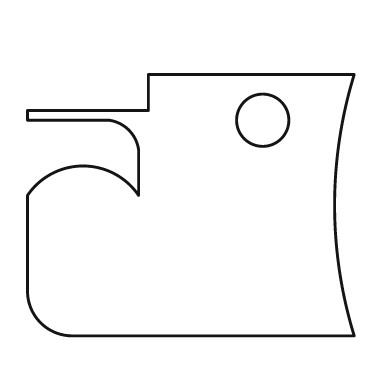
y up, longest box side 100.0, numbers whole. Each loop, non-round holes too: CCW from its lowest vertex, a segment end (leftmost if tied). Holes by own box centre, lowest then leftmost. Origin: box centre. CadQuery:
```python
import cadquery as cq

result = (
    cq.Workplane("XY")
    .moveTo(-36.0, -40.0)
    .lineTo(50.0, -40.0)
    .threePointArc((44.0, 0.0), (50.0, 40.0))
    .lineTo(-13.0, 40.0)
    .lineTo(-13.0, 29.0)
    .lineTo(-50.0, 29.0)
    .lineTo(-50.0, 26.0)
    .lineTo(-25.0, 26.0)
    .threePointArc((-19.0, 23.0), (-16.0, 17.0))
    .lineTo(-16.0, 3.0)
    .threePointArc((-33.0, 12.0), (-50.0, 3.0))
    .lineTo(-50.0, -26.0)
    .threePointArc((-46.0, -36.0), (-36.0, -40.0))
    .close()
    .moveTo(22.0, 26.0)
    .circle(8.0)
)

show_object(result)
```